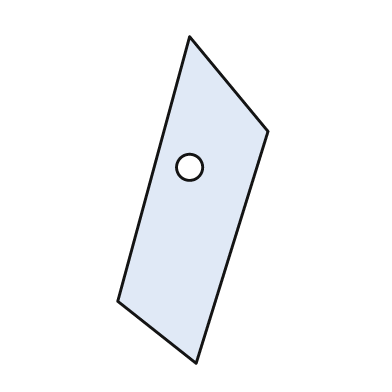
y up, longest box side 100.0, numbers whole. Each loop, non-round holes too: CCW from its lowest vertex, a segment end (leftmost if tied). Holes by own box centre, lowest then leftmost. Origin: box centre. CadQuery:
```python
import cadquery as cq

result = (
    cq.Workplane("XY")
    .moveTo(1.0, -50.0)
    .lineTo(23.0, 21.0)
    .lineTo(-1.0, 50.0)
    .lineTo(-23.0, -31.0)
    .close()
    .moveTo(-1.0, 10.0)
    .circle(4.0)
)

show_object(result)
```